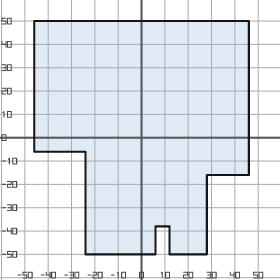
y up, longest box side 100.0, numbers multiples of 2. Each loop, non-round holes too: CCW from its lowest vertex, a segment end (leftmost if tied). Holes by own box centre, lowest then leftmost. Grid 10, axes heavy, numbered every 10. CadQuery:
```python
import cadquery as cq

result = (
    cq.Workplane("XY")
    .moveTo(-24.0, -50.0)
    .lineTo(6.0, -50.0)
    .lineTo(6.0, -38.0)
    .lineTo(12.0, -38.0)
    .lineTo(12.0, -50.0)
    .lineTo(28.0, -50.0)
    .lineTo(28.0, -16.0)
    .lineTo(46.0, -16.0)
    .lineTo(46.0, 50.0)
    .lineTo(-46.0, 50.0)
    .lineTo(-46.0, -6.0)
    .lineTo(-24.0, -6.0)
    .close()
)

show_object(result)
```